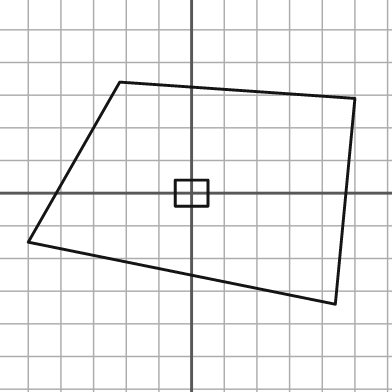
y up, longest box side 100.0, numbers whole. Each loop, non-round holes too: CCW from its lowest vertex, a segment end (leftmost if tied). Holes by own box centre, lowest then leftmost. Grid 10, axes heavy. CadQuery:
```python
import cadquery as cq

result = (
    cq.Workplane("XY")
    .moveTo(44.0, -34.0)
    .lineTo(50.0, 29.0)
    .lineTo(-22.0, 34.0)
    .lineTo(-50.0, -15.0)
    .close()
    .moveTo(-5.0, -4.0)
    .lineTo(5.0, -4.0)
    .lineTo(5.0, 4.0)
    .lineTo(-5.0, 4.0)
    .close()
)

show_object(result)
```